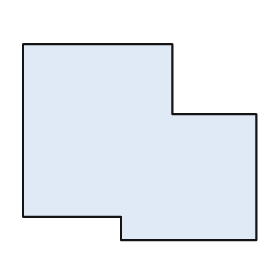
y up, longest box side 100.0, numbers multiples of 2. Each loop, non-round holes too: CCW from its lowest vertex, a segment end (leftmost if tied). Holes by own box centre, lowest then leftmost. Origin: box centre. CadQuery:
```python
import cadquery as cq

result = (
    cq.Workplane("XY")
    .moveTo(-8.0, -42.0)
    .lineTo(50.0, -42.0)
    .lineTo(50.0, 12.0)
    .lineTo(14.0, 12.0)
    .lineTo(14.0, 42.0)
    .lineTo(-50.0, 42.0)
    .lineTo(-50.0, -32.0)
    .lineTo(-8.0, -32.0)
    .close()
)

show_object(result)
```